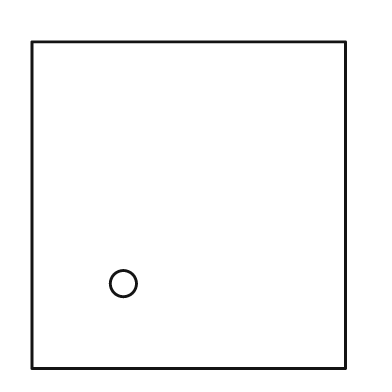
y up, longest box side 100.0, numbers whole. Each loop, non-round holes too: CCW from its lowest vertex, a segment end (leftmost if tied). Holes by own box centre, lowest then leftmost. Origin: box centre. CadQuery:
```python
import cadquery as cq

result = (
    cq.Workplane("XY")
    .moveTo(-48.0, -50.0)
    .lineTo(48.0, -50.0)
    .lineTo(48.0, 50.0)
    .lineTo(-48.0, 50.0)
    .close()
    .moveTo(-20.0, -24.0)
    .circle(4.0)
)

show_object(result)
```